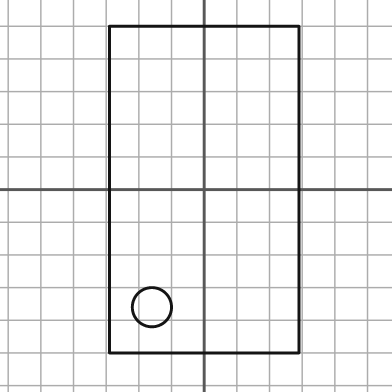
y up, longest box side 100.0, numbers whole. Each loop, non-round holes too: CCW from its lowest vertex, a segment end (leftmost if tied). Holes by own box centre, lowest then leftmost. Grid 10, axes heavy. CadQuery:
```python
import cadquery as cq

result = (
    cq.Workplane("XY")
    .moveTo(-29.0, -50.0)
    .lineTo(29.0, -50.0)
    .lineTo(29.0, 50.0)
    .lineTo(-29.0, 50.0)
    .close()
    .moveTo(-16.0, -36.0)
    .circle(6.0)
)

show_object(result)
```